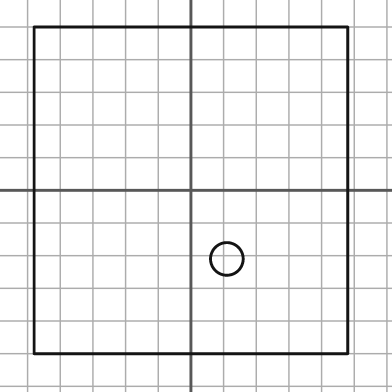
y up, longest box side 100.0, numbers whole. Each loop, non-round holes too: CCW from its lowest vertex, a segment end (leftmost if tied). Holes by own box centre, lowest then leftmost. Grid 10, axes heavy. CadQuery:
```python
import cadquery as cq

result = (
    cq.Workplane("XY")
    .moveTo(-48.0, -50.0)
    .lineTo(48.0, -50.0)
    .lineTo(48.0, 50.0)
    .lineTo(-48.0, 50.0)
    .close()
    .moveTo(11.0, -21.0)
    .circle(5.0)
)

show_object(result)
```